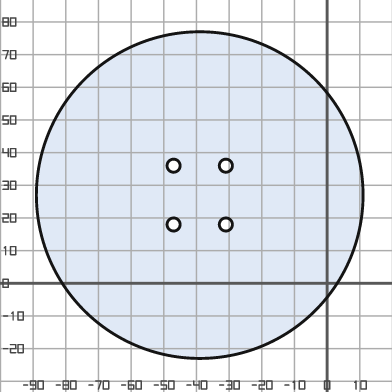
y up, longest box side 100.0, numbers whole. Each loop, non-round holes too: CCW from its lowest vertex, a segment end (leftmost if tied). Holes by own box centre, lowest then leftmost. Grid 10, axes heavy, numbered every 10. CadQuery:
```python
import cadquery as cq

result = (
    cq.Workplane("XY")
    .moveTo(-39.0, 27.0)
    .circle(50.0)
    .moveTo(-47.0, 18.0)
    .circle(2.0)
    .moveTo(-31.0, 18.0)
    .circle(2.0)
    .moveTo(-47.0, 36.0)
    .circle(2.0)
    .moveTo(-31.0, 36.0)
    .circle(2.0)
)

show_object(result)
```